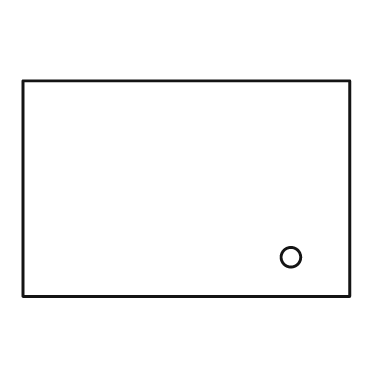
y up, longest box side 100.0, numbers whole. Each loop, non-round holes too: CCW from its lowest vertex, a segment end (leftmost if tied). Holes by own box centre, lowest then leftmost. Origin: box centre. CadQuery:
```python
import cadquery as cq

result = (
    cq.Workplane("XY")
    .moveTo(-50.0, -33.0)
    .lineTo(50.0, -33.0)
    .lineTo(50.0, 33.0)
    .lineTo(-50.0, 33.0)
    .close()
    .moveTo(32.0, -21.0)
    .circle(3.0)
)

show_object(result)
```